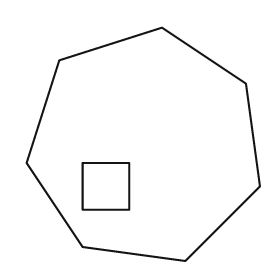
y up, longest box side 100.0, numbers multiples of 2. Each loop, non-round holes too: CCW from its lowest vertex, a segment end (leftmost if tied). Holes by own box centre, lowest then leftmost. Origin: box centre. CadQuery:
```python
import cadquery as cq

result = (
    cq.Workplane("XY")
    .moveTo(18.0, -50.0)
    .lineTo(50.0, -18.0)
    .lineTo(44.0, 26.0)
    .lineTo(8.0, 50.0)
    .lineTo(-36.0, 36.0)
    .lineTo(-50.0, -8.0)
    .lineTo(-26.0, -44.0)
    .close()
    .moveTo(-26.0, -28.0)
    .lineTo(-6.0, -28.0)
    .lineTo(-6.0, -8.0)
    .lineTo(-26.0, -8.0)
    .close()
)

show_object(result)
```